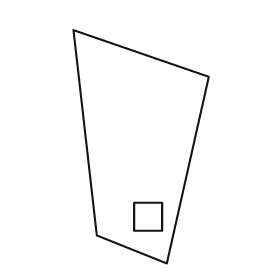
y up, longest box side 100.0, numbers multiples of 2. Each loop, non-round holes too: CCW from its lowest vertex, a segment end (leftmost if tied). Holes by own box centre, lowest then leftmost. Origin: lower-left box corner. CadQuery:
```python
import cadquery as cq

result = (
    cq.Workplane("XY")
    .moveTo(40.0, 0.0)
    .lineTo(58.0, 80.0)
    .lineTo(0.0, 100.0)
    .lineTo(10.0, 12.0)
    .close()
    .moveTo(26.0, 14.0)
    .lineTo(38.0, 14.0)
    .lineTo(38.0, 26.0)
    .lineTo(26.0, 26.0)
    .close()
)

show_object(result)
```